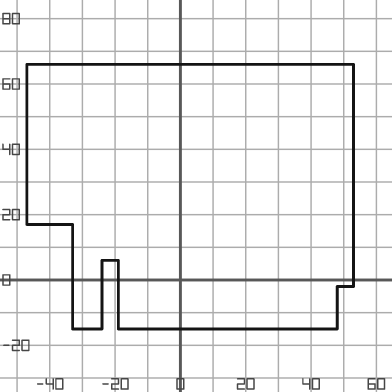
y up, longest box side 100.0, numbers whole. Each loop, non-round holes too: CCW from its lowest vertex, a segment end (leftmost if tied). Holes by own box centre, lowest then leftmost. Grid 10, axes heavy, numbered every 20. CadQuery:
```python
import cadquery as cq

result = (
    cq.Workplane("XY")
    .moveTo(-33.0, -15.0)
    .lineTo(-24.0, -15.0)
    .lineTo(-24.0, 6.0)
    .lineTo(-19.0, 6.0)
    .lineTo(-19.0, -15.0)
    .lineTo(48.0, -15.0)
    .lineTo(48.0, -2.0)
    .lineTo(53.0, -2.0)
    .lineTo(53.0, 66.0)
    .lineTo(-47.0, 66.0)
    .lineTo(-47.0, 17.0)
    .lineTo(-33.0, 17.0)
    .close()
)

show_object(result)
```